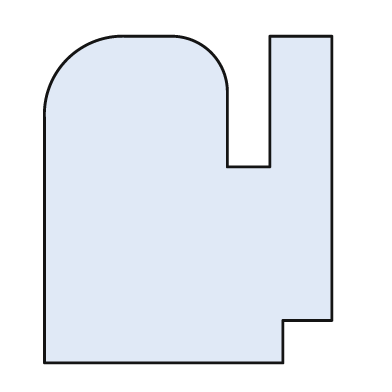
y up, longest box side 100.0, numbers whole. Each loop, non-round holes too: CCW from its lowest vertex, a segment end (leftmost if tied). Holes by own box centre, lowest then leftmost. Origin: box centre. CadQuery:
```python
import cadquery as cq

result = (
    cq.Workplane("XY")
    .moveTo(-44.0, -50.0)
    .lineTo(29.0, -50.0)
    .lineTo(29.0, -37.0)
    .lineTo(44.0, -37.0)
    .lineTo(44.0, 50.0)
    .lineTo(25.0, 50.0)
    .lineTo(25.0, 10.0)
    .lineTo(12.0, 10.0)
    .lineTo(12.0, 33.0)
    .threePointArc((7.0, 45.0), (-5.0, 50.0))
    .lineTo(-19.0, 50.0)
    .threePointArc((-37.0, 43.0), (-44.0, 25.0))
    .close()
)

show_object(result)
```